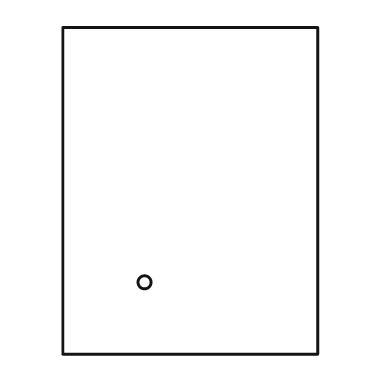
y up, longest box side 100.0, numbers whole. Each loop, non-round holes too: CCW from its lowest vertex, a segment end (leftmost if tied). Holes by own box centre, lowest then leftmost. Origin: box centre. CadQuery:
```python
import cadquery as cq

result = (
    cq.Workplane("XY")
    .moveTo(-39.0, -50.0)
    .lineTo(39.0, -50.0)
    .lineTo(39.0, 50.0)
    .lineTo(-39.0, 50.0)
    .close()
    .moveTo(-14.0, -28.0)
    .circle(2.0)
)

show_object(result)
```